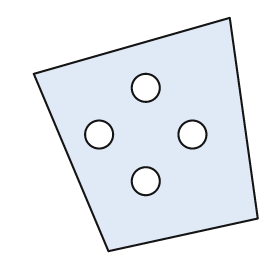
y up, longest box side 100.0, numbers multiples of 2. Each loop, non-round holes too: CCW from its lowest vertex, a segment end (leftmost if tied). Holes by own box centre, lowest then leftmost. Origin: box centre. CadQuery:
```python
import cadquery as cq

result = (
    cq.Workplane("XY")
    .moveTo(-16.0, -50.0)
    .lineTo(48.0, -36.0)
    .lineTo(36.0, 50.0)
    .lineTo(-48.0, 26.0)
    .close()
    .moveTo(0.0, -20.0)
    .circle(6.0)
    .moveTo(-20.0, 0.0)
    .circle(6.0)
    .moveTo(20.0, 0.0)
    .circle(6.0)
    .moveTo(0.0, 20.0)
    .circle(6.0)
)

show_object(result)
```